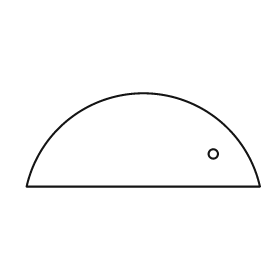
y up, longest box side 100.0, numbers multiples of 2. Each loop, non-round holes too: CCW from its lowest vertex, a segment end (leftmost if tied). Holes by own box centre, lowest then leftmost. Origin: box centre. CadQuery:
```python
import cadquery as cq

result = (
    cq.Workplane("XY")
    .moveTo(-50.0, -20.0)
    .lineTo(50.0, -20.0)
    .threePointArc((0.0, 20.0), (-50.0, -20.0))
    .close()
    .moveTo(30.0, -6.0)
    .circle(2.0)
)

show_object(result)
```